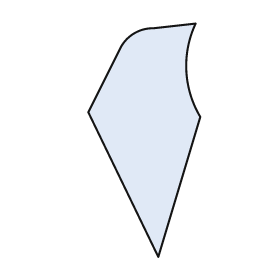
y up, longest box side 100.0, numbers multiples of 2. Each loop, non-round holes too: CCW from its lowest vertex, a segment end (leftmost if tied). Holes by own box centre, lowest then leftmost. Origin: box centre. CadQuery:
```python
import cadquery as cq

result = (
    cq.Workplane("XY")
    .moveTo(6.0, -50.0)
    .lineTo(24.0, 10.0)
    .threePointArc((18.0, 30.0), (22.0, 50.0))
    .lineTo(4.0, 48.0)
    .threePointArc((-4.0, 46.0), (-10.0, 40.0))
    .lineTo(-24.0, 12.0)
    .close()
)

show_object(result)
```